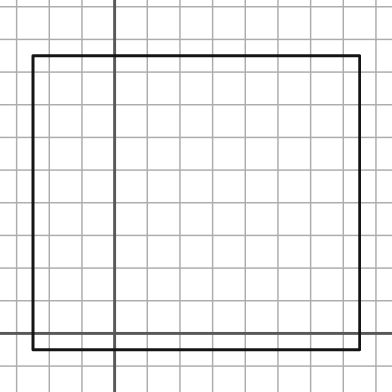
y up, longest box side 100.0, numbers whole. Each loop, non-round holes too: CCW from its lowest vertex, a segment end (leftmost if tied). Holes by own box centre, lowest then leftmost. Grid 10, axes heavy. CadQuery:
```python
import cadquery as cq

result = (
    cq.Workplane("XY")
    .moveTo(-25.0, -5.0)
    .lineTo(75.0, -5.0)
    .lineTo(75.0, 85.0)
    .lineTo(-25.0, 85.0)
    .close()
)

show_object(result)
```